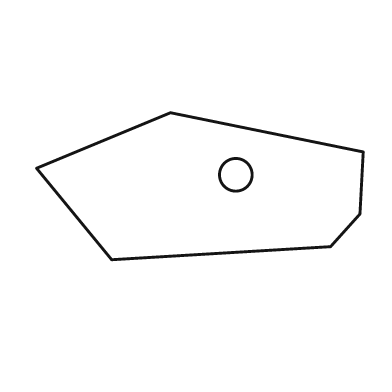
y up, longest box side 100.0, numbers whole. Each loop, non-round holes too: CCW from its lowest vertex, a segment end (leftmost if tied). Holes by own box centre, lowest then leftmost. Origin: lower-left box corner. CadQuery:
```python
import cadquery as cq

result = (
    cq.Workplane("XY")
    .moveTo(23.0, 0.0)
    .lineTo(90.0, 4.0)
    .lineTo(99.0, 14.0)
    .lineTo(100.0, 33.0)
    .lineTo(41.0, 45.0)
    .lineTo(0.0, 28.0)
    .close()
    .moveTo(61.0, 26.0)
    .circle(5.0)
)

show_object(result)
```